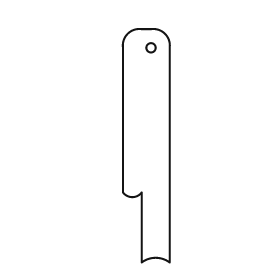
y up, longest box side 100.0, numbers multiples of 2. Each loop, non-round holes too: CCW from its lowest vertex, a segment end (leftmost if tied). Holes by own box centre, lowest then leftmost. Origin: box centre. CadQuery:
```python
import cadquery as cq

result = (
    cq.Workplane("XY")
    .moveTo(-2.0, -50.0)
    .threePointArc((4.0, -48.0), (10.0, -50.0))
    .lineTo(10.0, 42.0)
    .threePointArc((8.0, 48.0), (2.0, 50.0))
    .lineTo(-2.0, 50.0)
    .threePointArc((-8.0, 48.0), (-10.0, 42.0))
    .lineTo(-10.0, -20.0)
    .threePointArc((-6.0, -22.0), (-2.0, -20.0))
    .close()
    .moveTo(2.0, 42.0)
    .circle(2.0)
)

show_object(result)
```